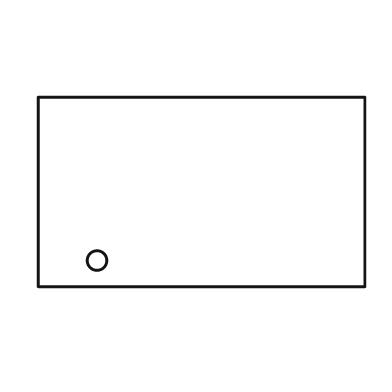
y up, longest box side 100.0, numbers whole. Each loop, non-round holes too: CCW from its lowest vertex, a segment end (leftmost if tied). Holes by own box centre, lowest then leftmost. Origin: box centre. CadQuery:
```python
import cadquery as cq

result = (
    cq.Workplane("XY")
    .moveTo(-50.0, -29.0)
    .lineTo(50.0, -29.0)
    .lineTo(50.0, 29.0)
    .lineTo(-50.0, 29.0)
    .close()
    .moveTo(-32.0, -21.0)
    .circle(3.0)
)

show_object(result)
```